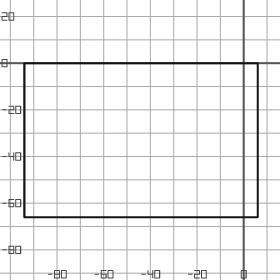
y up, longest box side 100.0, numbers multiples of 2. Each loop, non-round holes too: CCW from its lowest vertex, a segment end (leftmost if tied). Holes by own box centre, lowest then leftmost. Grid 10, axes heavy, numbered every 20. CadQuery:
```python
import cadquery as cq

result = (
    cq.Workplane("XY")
    .moveTo(-94.0, -66.0)
    .lineTo(6.0, -66.0)
    .lineTo(6.0, 0.0)
    .lineTo(-94.0, 0.0)
    .close()
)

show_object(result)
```